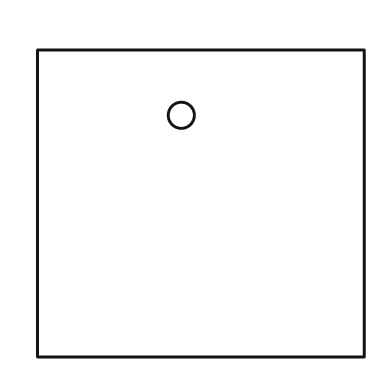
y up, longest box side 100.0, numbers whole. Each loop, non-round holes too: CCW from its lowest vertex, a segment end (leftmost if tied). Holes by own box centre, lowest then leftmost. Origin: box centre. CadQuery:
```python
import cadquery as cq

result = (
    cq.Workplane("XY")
    .moveTo(-50.0, -47.0)
    .lineTo(50.0, -47.0)
    .lineTo(50.0, 47.0)
    .lineTo(-50.0, 47.0)
    .close()
    .moveTo(-6.0, 27.0)
    .circle(4.0)
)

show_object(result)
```